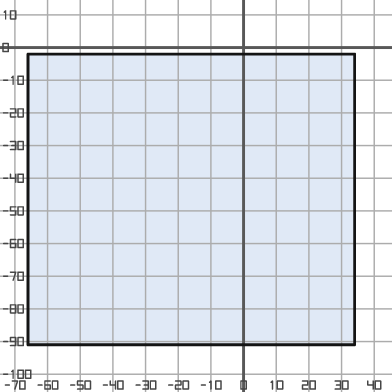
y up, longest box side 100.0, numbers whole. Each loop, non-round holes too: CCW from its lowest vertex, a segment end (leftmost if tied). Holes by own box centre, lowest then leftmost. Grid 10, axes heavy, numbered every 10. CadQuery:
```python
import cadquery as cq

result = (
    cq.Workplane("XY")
    .moveTo(-66.0, -91.0)
    .lineTo(34.0, -91.0)
    .lineTo(34.0, -2.0)
    .lineTo(-66.0, -2.0)
    .close()
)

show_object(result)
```